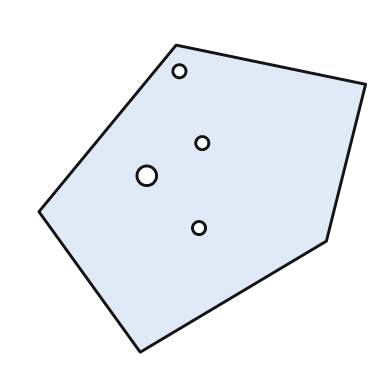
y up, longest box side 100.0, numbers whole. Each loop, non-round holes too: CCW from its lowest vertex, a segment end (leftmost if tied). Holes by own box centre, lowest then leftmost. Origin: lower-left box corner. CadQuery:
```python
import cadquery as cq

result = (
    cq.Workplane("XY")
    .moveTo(31.0, 0.0)
    .lineTo(88.0, 34.0)
    .lineTo(100.0, 82.0)
    .lineTo(42.0, 94.0)
    .lineTo(0.0, 43.0)
    .close()
    .moveTo(49.0, 38.0)
    .circle(2.0)
    .moveTo(33.0, 54.0)
    .circle(3.0)
    .moveTo(50.0, 64.0)
    .circle(2.0)
    .moveTo(43.0, 86.0)
    .circle(2.0)
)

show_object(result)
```